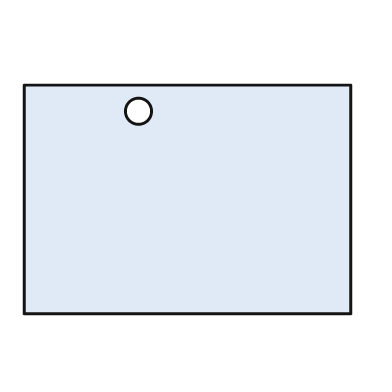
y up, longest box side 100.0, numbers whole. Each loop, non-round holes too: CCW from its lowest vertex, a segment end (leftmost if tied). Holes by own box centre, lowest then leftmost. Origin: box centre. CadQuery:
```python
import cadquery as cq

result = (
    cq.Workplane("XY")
    .moveTo(-50.0, -35.0)
    .lineTo(50.0, -35.0)
    .lineTo(50.0, 35.0)
    .lineTo(-50.0, 35.0)
    .close()
    .moveTo(-15.0, 27.0)
    .circle(4.0)
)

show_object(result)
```